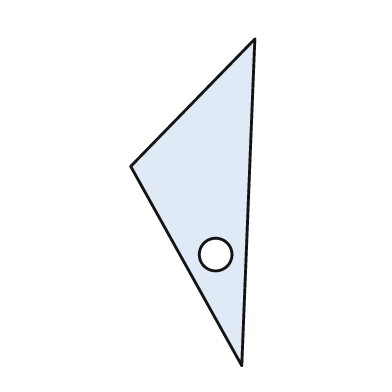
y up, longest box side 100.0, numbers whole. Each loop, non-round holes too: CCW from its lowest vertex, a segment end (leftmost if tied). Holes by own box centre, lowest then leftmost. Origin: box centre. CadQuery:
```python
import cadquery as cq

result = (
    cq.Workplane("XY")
    .moveTo(15.0, -50.0)
    .lineTo(19.0, 50.0)
    .lineTo(-19.0, 11.0)
    .close()
    .moveTo(7.0, -16.0)
    .circle(5.0)
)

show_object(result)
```